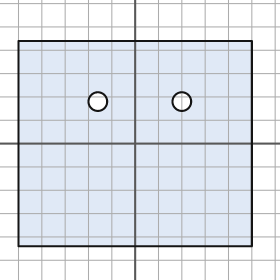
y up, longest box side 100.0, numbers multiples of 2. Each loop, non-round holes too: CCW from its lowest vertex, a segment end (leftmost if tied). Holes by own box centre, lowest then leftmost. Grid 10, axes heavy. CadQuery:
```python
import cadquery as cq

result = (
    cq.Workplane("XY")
    .moveTo(-50.0, -44.0)
    .lineTo(50.0, -44.0)
    .lineTo(50.0, 44.0)
    .lineTo(-50.0, 44.0)
    .close()
    .moveTo(-16.0, 18.0)
    .circle(4.0)
    .moveTo(20.0, 18.0)
    .circle(4.0)
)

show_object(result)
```